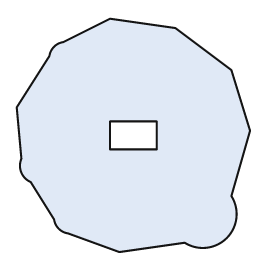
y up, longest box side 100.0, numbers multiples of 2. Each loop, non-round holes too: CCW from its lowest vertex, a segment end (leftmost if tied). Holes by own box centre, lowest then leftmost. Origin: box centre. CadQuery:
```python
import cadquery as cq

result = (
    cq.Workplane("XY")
    .moveTo(-6.0, -50.0)
    .lineTo(22.0, -46.0)
    .threePointArc((40.0, -44.0), (42.0, -26.0))
    .lineTo(50.0, 2.0)
    .lineTo(42.0, 28.0)
    .lineTo(18.0, 46.0)
    .lineTo(-10.0, 50.0)
    .lineTo(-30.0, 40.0)
    .threePointArc((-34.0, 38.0), (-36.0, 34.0))
    .lineTo(-50.0, 12.0)
    .lineTo(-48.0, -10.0)
    .threePointArc((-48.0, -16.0), (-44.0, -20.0))
    .lineTo(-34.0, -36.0)
    .threePointArc((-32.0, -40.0), (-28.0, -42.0))
    .close()
    .moveTo(-10.0, -6.0)
    .lineTo(10.0, -6.0)
    .lineTo(10.0, 6.0)
    .lineTo(-10.0, 6.0)
    .close()
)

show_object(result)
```